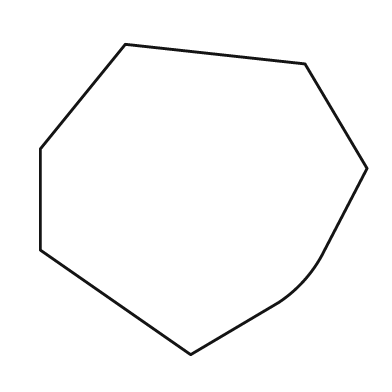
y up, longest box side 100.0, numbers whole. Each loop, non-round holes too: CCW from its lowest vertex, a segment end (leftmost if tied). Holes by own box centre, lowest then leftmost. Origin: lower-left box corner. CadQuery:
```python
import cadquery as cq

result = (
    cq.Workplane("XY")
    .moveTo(46.0, 0.0)
    .lineTo(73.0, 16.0)
    .threePointArc((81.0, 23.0), (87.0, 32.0))
    .lineTo(100.0, 57.0)
    .lineTo(81.0, 89.0)
    .lineTo(26.0, 95.0)
    .lineTo(0.0, 63.0)
    .lineTo(0.0, 32.0)
    .close()
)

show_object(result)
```